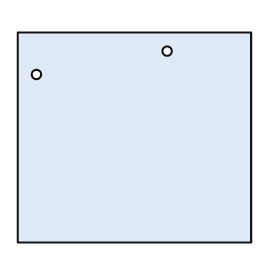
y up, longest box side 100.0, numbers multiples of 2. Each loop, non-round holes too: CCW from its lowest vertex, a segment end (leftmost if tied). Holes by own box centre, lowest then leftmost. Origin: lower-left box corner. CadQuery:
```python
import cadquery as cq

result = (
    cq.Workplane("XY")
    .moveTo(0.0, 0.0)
    .lineTo(100.0, 0.0)
    .lineTo(100.0, 90.0)
    .lineTo(0.0, 90.0)
    .close()
    .moveTo(8.0, 72.0)
    .circle(2.0)
    .moveTo(64.0, 82.0)
    .circle(2.0)
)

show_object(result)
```